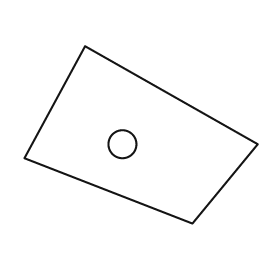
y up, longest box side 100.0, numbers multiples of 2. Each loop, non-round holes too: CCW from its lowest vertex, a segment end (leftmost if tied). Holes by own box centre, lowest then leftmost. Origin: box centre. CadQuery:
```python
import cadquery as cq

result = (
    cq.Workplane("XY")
    .moveTo(22.0, -38.0)
    .lineTo(50.0, -4.0)
    .lineTo(-24.0, 38.0)
    .lineTo(-50.0, -10.0)
    .close()
    .moveTo(-8.0, -4.0)
    .circle(6.0)
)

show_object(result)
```